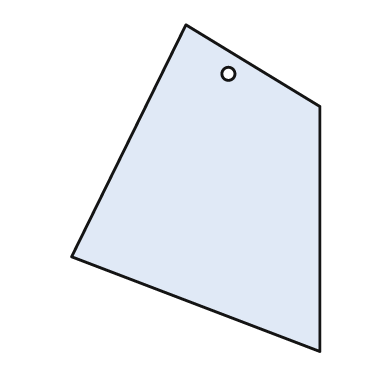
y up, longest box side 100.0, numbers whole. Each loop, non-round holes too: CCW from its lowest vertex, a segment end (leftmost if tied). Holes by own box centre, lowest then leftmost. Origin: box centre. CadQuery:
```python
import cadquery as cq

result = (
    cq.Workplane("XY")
    .moveTo(38.0, -50.0)
    .lineTo(38.0, 25.0)
    .lineTo(-3.0, 50.0)
    .lineTo(-38.0, -21.0)
    .close()
    .moveTo(10.0, 35.0)
    .circle(2.0)
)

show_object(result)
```